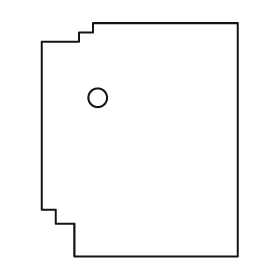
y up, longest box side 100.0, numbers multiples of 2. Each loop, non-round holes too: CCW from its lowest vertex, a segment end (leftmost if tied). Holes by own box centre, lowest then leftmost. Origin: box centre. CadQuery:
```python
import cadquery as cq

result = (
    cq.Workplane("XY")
    .moveTo(-28.0, -50.0)
    .lineTo(42.0, -50.0)
    .lineTo(42.0, 50.0)
    .lineTo(-20.0, 50.0)
    .lineTo(-20.0, 46.0)
    .lineTo(-26.0, 46.0)
    .lineTo(-26.0, 42.0)
    .lineTo(-42.0, 42.0)
    .lineTo(-42.0, -30.0)
    .lineTo(-36.0, -30.0)
    .lineTo(-36.0, -36.0)
    .lineTo(-28.0, -36.0)
    .close()
    .moveTo(-18.0, 18.0)
    .circle(4.0)
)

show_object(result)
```